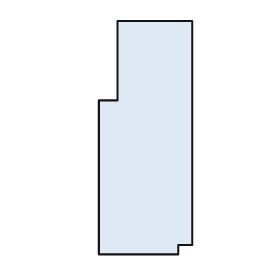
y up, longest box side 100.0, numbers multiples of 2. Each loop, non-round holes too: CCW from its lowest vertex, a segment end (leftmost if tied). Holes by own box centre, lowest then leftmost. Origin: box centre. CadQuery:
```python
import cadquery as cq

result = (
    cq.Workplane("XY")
    .moveTo(-20.0, -50.0)
    .lineTo(14.0, -50.0)
    .lineTo(14.0, -46.0)
    .lineTo(20.0, -46.0)
    .lineTo(20.0, 50.0)
    .lineTo(-12.0, 50.0)
    .lineTo(-12.0, 16.0)
    .lineTo(-20.0, 16.0)
    .close()
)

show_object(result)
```